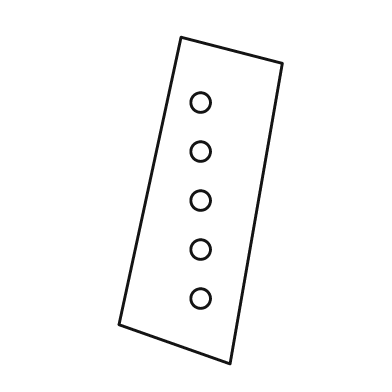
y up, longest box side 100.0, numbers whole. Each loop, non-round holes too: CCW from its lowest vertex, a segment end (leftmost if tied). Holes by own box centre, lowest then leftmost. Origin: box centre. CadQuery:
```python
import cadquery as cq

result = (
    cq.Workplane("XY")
    .moveTo(9.0, -50.0)
    .lineTo(25.0, 42.0)
    .lineTo(-6.0, 50.0)
    .lineTo(-25.0, -38.0)
    .close()
    .moveTo(0.0, -30.0)
    .circle(3.0)
    .moveTo(0.0, -15.0)
    .circle(3.0)
    .moveTo(0.0, 0.0)
    .circle(3.0)
    .moveTo(0.0, 15.0)
    .circle(3.0)
    .moveTo(0.0, 30.0)
    .circle(3.0)
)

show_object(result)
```